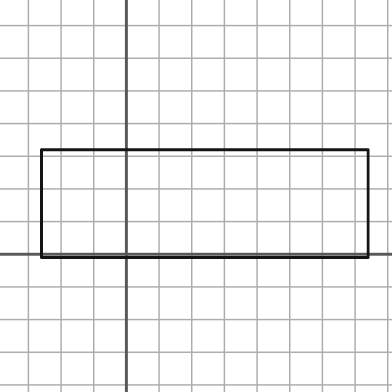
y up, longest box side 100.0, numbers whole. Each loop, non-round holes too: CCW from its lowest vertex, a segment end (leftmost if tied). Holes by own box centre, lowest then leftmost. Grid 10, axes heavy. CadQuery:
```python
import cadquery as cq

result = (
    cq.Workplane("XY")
    .moveTo(-26.0, -1.0)
    .lineTo(74.0, -1.0)
    .lineTo(74.0, 32.0)
    .lineTo(-26.0, 32.0)
    .close()
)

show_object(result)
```